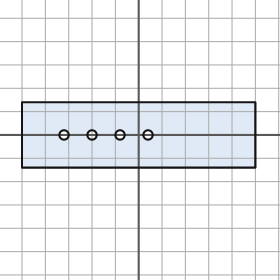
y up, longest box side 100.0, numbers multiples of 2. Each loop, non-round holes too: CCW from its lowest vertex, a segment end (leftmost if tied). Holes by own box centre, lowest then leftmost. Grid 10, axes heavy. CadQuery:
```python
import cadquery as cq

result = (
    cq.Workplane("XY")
    .moveTo(-50.0, -14.0)
    .lineTo(50.0, -14.0)
    .lineTo(50.0, 14.0)
    .lineTo(-50.0, 14.0)
    .close()
    .moveTo(-32.0, 0.0)
    .circle(2.0)
    .moveTo(-20.0, 0.0)
    .circle(2.0)
    .moveTo(-8.0, 0.0)
    .circle(2.0)
    .moveTo(4.0, 0.0)
    .circle(2.0)
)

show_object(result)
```